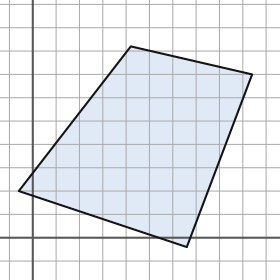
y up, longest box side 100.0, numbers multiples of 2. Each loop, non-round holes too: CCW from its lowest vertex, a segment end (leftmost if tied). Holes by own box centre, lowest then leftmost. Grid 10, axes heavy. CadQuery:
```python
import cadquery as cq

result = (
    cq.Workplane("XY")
    .moveTo(66.0, -4.0)
    .lineTo(94.0, 70.0)
    .lineTo(42.0, 82.0)
    .lineTo(-6.0, 20.0)
    .close()
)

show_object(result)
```